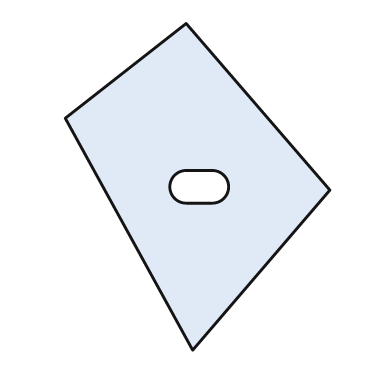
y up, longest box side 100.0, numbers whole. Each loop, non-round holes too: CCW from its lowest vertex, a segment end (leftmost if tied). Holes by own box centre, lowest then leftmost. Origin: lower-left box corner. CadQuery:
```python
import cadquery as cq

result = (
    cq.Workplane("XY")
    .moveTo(39.0, 0.0)
    .lineTo(81.0, 49.0)
    .lineTo(37.0, 100.0)
    .lineTo(0.0, 71.0)
    .close()
    .moveTo(37.0, 45.0)
    .lineTo(45.0, 45.0)
    .threePointArc((50.0, 50.0), (45.0, 55.0))
    .lineTo(37.0, 55.0)
    .threePointArc((32.0, 50.0), (37.0, 45.0))
    .close()
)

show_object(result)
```